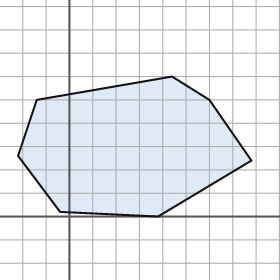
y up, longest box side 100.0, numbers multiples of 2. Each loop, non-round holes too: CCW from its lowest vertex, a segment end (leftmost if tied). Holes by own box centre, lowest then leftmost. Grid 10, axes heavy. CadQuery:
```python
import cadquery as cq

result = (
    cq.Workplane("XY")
    .moveTo(38.0, 0.0)
    .lineTo(78.0, 24.0)
    .lineTo(60.0, 50.0)
    .lineTo(44.0, 60.0)
    .lineTo(-14.0, 50.0)
    .lineTo(-22.0, 26.0)
    .lineTo(-4.0, 2.0)
    .close()
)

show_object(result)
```